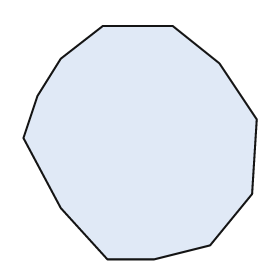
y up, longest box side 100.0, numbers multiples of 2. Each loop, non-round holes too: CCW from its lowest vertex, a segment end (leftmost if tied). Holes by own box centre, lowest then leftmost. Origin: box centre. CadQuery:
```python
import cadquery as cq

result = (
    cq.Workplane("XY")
    .moveTo(-14.0, -50.0)
    .lineTo(6.0, -50.0)
    .lineTo(30.0, -44.0)
    .lineTo(48.0, -22.0)
    .lineTo(50.0, 10.0)
    .lineTo(34.0, 34.0)
    .lineTo(14.0, 50.0)
    .lineTo(-16.0, 50.0)
    .lineTo(-34.0, 36.0)
    .lineTo(-44.0, 20.0)
    .lineTo(-50.0, 2.0)
    .lineTo(-34.0, -28.0)
    .close()
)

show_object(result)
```